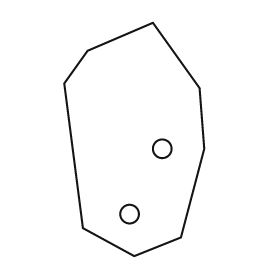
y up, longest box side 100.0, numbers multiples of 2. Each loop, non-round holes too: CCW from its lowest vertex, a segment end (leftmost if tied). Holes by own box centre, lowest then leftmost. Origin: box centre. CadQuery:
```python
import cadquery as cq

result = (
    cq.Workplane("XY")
    .moveTo(0.0, -50.0)
    .lineTo(20.0, -42.0)
    .lineTo(30.0, -4.0)
    .lineTo(28.0, 22.0)
    .lineTo(8.0, 50.0)
    .lineTo(-20.0, 38.0)
    .lineTo(-30.0, 24.0)
    .lineTo(-22.0, -38.0)
    .close()
    .moveTo(-2.0, -32.0)
    .circle(4.0)
    .moveTo(12.0, -4.0)
    .circle(4.0)
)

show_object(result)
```